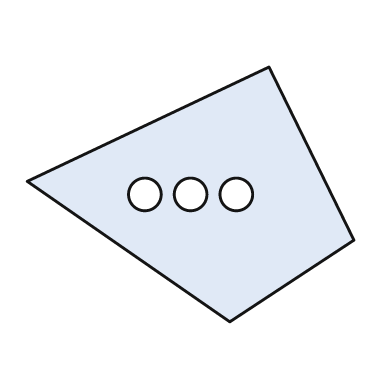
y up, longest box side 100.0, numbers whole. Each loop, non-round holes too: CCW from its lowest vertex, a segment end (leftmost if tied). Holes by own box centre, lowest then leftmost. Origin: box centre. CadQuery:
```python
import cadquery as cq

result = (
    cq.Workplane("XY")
    .moveTo(12.0, -39.0)
    .lineTo(50.0, -14.0)
    .lineTo(24.0, 39.0)
    .lineTo(-50.0, 4.0)
    .close()
    .moveTo(-14.0, 0.0)
    .circle(5.0)
    .moveTo(0.0, 0.0)
    .circle(5.0)
    .moveTo(14.0, 0.0)
    .circle(5.0)
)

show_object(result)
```